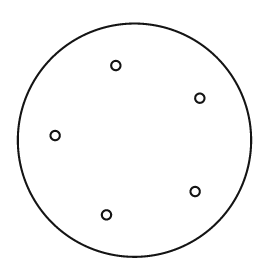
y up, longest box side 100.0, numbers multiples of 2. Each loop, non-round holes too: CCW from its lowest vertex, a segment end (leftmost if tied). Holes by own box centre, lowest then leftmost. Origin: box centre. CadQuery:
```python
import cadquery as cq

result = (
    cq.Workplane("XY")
    .moveTo(0.0, 0.0)
    .circle(50.0)
    .moveTo(-12.0, -32.0)
    .circle(2.0)
    .moveTo(26.0, -22.0)
    .circle(2.0)
    .moveTo(-34.0, 2.0)
    .circle(2.0)
    .moveTo(28.0, 18.0)
    .circle(2.0)
    .moveTo(-8.0, 32.0)
    .circle(2.0)
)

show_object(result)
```